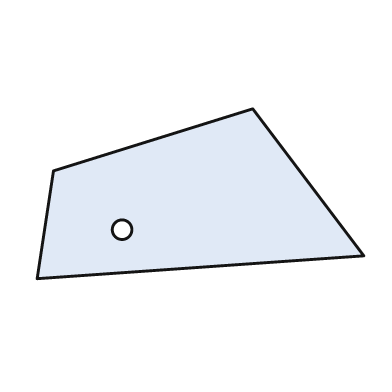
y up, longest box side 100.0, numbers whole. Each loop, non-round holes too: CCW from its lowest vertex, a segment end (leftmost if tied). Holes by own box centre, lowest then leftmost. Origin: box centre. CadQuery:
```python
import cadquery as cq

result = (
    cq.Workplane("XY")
    .moveTo(-50.0, -26.0)
    .lineTo(50.0, -19.0)
    .lineTo(16.0, 26.0)
    .lineTo(-45.0, 7.0)
    .close()
    .moveTo(-24.0, -11.0)
    .circle(3.0)
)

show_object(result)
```